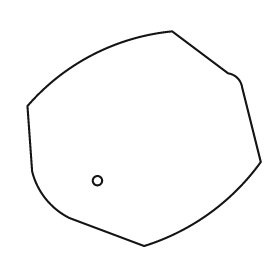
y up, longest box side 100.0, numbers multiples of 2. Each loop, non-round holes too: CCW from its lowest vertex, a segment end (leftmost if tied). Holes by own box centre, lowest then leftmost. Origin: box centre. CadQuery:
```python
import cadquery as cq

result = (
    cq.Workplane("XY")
    .moveTo(0.0, -46.0)
    .threePointArc((28.0, -32.0), (50.0, -10.0))
    .lineTo(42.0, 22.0)
    .threePointArc((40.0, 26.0), (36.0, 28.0))
    .lineTo(12.0, 46.0)
    .threePointArc((-22.0, 36.0), (-50.0, 14.0))
    .lineTo(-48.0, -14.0)
    .threePointArc((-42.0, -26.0), (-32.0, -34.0))
    .close()
    .moveTo(-20.0, -18.0)
    .circle(2.0)
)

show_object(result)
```